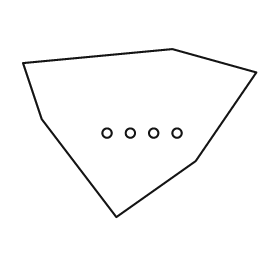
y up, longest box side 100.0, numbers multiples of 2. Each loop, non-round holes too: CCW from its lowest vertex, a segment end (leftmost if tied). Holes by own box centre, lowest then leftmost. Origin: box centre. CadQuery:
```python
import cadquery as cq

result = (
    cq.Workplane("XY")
    .moveTo(-10.0, -36.0)
    .lineTo(24.0, -12.0)
    .lineTo(50.0, 26.0)
    .lineTo(14.0, 36.0)
    .lineTo(-50.0, 30.0)
    .lineTo(-42.0, 6.0)
    .close()
    .moveTo(-14.0, 0.0)
    .circle(2.0)
    .moveTo(-4.0, 0.0)
    .circle(2.0)
    .moveTo(6.0, 0.0)
    .circle(2.0)
    .moveTo(16.0, 0.0)
    .circle(2.0)
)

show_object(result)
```